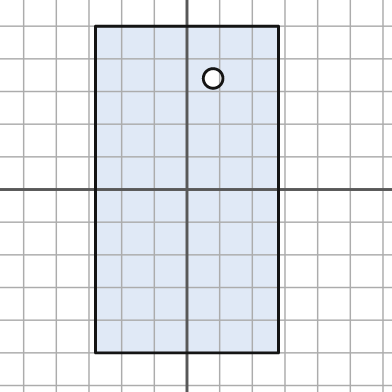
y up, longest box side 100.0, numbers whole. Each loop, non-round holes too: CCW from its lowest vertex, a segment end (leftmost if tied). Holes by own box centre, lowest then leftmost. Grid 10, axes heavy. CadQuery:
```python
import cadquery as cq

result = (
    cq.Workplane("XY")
    .moveTo(-28.0, -50.0)
    .lineTo(28.0, -50.0)
    .lineTo(28.0, 50.0)
    .lineTo(-28.0, 50.0)
    .close()
    .moveTo(8.0, 34.0)
    .circle(3.0)
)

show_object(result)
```